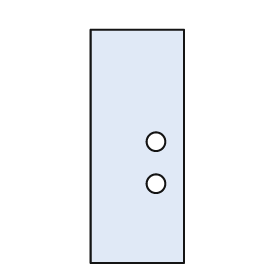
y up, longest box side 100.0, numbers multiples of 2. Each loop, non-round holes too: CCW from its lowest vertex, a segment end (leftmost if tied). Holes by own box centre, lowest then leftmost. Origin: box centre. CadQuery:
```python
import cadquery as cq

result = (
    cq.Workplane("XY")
    .moveTo(-20.0, -50.0)
    .lineTo(20.0, -50.0)
    .lineTo(20.0, 50.0)
    .lineTo(-20.0, 50.0)
    .close()
    .moveTo(8.0, -16.0)
    .circle(4.0)
    .moveTo(8.0, 2.0)
    .circle(4.0)
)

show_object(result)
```